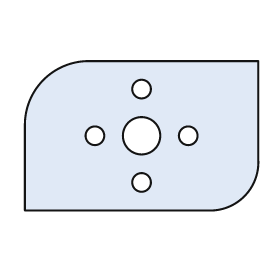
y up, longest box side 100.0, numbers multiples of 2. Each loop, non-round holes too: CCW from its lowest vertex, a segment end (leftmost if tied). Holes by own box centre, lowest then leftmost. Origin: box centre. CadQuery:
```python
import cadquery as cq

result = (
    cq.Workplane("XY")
    .moveTo(-50.0, -32.0)
    .lineTo(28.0, -32.0)
    .threePointArc((44.0, -26.0), (50.0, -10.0))
    .lineTo(50.0, 32.0)
    .lineTo(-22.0, 32.0)
    .threePointArc((-42.0, 24.0), (-50.0, 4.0))
    .close()
    .moveTo(0.0, -20.0)
    .circle(4.0)
    .moveTo(-20.0, 0.0)
    .circle(4.0)
    .moveTo(0.0, 0.0)
    .circle(8.0)
    .moveTo(20.0, 0.0)
    .circle(4.0)
    .moveTo(0.0, 20.0)
    .circle(4.0)
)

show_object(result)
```